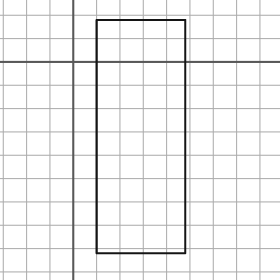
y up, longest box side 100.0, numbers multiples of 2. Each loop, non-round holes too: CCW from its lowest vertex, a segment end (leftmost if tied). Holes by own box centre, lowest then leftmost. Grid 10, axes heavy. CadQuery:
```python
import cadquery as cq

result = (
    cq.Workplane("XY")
    .moveTo(10.0, -82.0)
    .lineTo(48.0, -82.0)
    .lineTo(48.0, 18.0)
    .lineTo(10.0, 18.0)
    .close()
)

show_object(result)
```